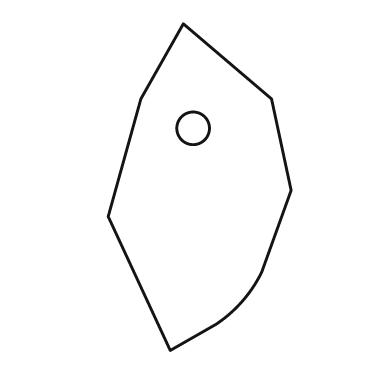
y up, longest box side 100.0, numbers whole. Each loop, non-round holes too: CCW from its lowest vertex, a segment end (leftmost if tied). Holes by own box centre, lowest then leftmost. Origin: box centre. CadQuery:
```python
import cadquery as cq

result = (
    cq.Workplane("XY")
    .moveTo(-9.0, -50.0)
    .lineTo(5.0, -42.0)
    .threePointArc((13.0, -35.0), (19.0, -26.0))
    .lineTo(28.0, -1.0)
    .lineTo(22.0, 27.0)
    .lineTo(-5.0, 50.0)
    .lineTo(-18.0, 27.0)
    .lineTo(-28.0, -9.0)
    .close()
    .moveTo(-2.0, 18.0)
    .circle(5.0)
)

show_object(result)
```